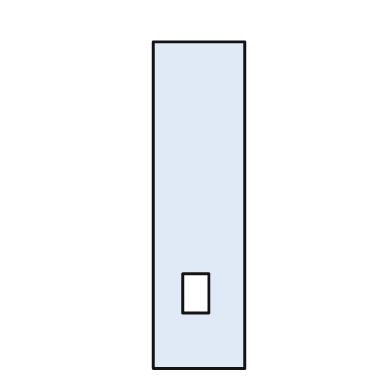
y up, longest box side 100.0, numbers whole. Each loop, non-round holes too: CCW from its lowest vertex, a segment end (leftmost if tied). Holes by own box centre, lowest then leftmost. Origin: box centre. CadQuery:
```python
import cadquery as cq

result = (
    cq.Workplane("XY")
    .moveTo(-14.0, -50.0)
    .lineTo(14.0, -50.0)
    .lineTo(14.0, 50.0)
    .lineTo(-14.0, 50.0)
    .close()
    .moveTo(-5.0, -33.0)
    .lineTo(3.0, -33.0)
    .lineTo(3.0, -21.0)
    .lineTo(-5.0, -21.0)
    .close()
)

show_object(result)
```